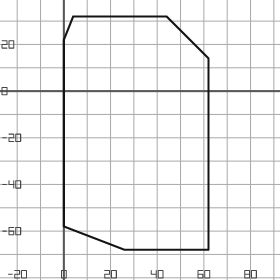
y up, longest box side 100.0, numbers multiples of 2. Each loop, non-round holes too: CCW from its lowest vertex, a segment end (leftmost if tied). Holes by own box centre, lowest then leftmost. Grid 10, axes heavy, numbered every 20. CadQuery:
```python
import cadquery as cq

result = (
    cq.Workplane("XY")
    .moveTo(26.0, -68.0)
    .lineTo(62.0, -68.0)
    .lineTo(62.0, 14.0)
    .lineTo(44.0, 32.0)
    .lineTo(4.0, 32.0)
    .lineTo(0.0, 22.0)
    .lineTo(0.0, -58.0)
    .close()
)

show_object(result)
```